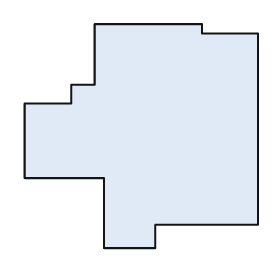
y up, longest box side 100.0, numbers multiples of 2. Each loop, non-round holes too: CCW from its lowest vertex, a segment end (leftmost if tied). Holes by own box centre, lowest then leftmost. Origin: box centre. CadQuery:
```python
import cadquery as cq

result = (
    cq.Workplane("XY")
    .moveTo(-16.0, -48.0)
    .lineTo(6.0, -48.0)
    .lineTo(6.0, -38.0)
    .lineTo(50.0, -38.0)
    .lineTo(50.0, 44.0)
    .lineTo(26.0, 44.0)
    .lineTo(26.0, 48.0)
    .lineTo(-20.0, 48.0)
    .lineTo(-20.0, 22.0)
    .lineTo(-30.0, 22.0)
    .lineTo(-30.0, 14.0)
    .lineTo(-50.0, 14.0)
    .lineTo(-50.0, -18.0)
    .lineTo(-16.0, -18.0)
    .close()
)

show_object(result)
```